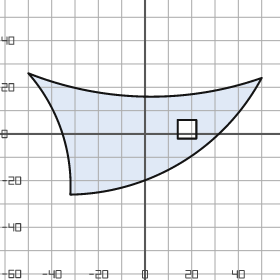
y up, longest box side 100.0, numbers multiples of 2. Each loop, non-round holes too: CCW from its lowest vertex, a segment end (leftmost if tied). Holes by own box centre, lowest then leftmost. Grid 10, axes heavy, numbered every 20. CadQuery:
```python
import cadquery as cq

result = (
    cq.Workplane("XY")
    .moveTo(-32.0, -26.0)
    .threePointArc((16.0, -12.0), (50.0, 24.0))
    .threePointArc((0.0, 16.0), (-50.0, 26.0))
    .threePointArc((-36.0, 2.0), (-32.0, -26.0))
    .close()
    .moveTo(14.0, -2.0)
    .lineTo(22.0, -2.0)
    .lineTo(22.0, 6.0)
    .lineTo(14.0, 6.0)
    .close()
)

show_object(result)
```